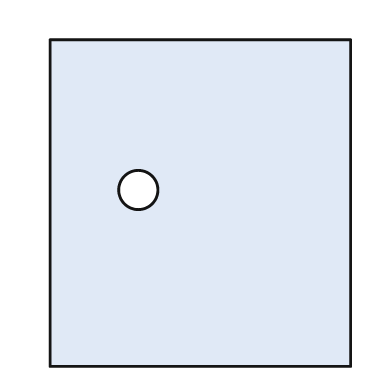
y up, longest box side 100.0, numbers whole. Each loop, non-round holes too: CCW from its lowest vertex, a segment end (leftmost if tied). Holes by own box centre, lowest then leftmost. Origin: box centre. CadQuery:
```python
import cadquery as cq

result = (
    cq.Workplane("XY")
    .moveTo(-46.0, -50.0)
    .lineTo(46.0, -50.0)
    .lineTo(46.0, 50.0)
    .lineTo(-46.0, 50.0)
    .close()
    .moveTo(-19.0, 4.0)
    .circle(6.0)
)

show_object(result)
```